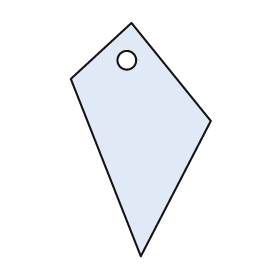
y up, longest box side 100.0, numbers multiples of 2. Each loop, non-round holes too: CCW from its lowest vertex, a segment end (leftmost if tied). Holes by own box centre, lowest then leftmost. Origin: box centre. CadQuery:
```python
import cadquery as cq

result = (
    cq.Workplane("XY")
    .moveTo(0.0, -50.0)
    .lineTo(30.0, 8.0)
    .lineTo(-4.0, 50.0)
    .lineTo(-30.0, 26.0)
    .close()
    .moveTo(-6.0, 34.0)
    .circle(4.0)
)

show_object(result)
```